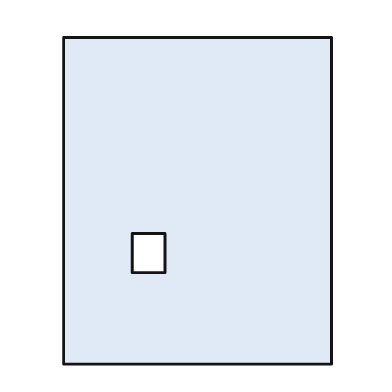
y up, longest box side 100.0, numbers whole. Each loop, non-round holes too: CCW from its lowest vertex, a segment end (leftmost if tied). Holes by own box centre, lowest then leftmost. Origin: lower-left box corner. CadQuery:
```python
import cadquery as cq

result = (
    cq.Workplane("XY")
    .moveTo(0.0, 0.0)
    .lineTo(82.0, 0.0)
    .lineTo(82.0, 100.0)
    .lineTo(0.0, 100.0)
    .close()
    .moveTo(21.0, 28.0)
    .lineTo(31.0, 28.0)
    .lineTo(31.0, 40.0)
    .lineTo(21.0, 40.0)
    .close()
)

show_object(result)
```